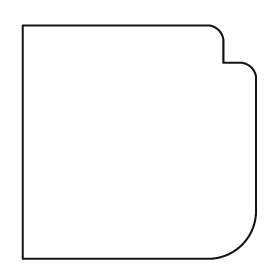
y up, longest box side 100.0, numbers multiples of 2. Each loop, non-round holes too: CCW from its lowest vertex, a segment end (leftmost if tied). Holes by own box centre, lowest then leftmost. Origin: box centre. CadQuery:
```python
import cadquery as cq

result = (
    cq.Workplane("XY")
    .moveTo(-50.0, -50.0)
    .lineTo(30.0, -50.0)
    .threePointArc((44.0, -44.0), (50.0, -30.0))
    .lineTo(50.0, 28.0)
    .threePointArc((48.0, 32.0), (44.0, 34.0))
    .lineTo(36.0, 34.0)
    .lineTo(36.0, 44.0)
    .threePointArc((34.0, 48.0), (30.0, 50.0))
    .lineTo(-50.0, 50.0)
    .close()
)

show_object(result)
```